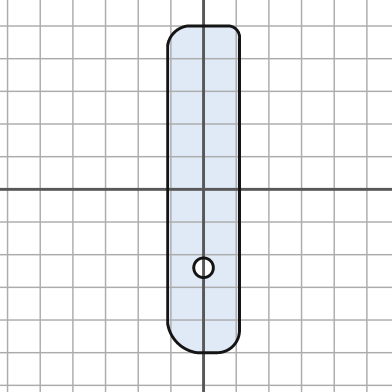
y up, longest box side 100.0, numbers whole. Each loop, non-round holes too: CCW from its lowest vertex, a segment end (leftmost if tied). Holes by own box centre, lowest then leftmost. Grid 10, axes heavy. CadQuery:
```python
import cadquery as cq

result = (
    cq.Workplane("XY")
    .moveTo(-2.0, -50.0)
    .lineTo(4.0, -50.0)
    .threePointArc((9.0, -48.0), (11.0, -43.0))
    .lineTo(11.0, 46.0)
    .threePointArc((10.0, 49.0), (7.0, 50.0))
    .lineTo(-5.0, 50.0)
    .threePointArc((-9.0, 48.0), (-11.0, 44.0))
    .lineTo(-11.0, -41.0)
    .threePointArc((-8.0, -47.0), (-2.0, -50.0))
    .close()
    .moveTo(0.0, -24.0)
    .circle(3.0)
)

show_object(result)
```